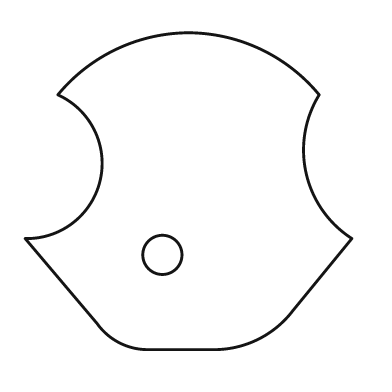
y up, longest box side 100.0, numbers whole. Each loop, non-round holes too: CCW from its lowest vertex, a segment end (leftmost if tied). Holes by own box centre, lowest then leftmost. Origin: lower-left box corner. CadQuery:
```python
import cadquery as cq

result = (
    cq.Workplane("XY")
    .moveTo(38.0, 0.0)
    .lineTo(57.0, 0.0)
    .threePointArc((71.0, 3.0), (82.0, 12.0))
    .lineTo(100.0, 34.0)
    .threePointArc((86.0, 54.0), (90.0, 78.0))
    .threePointArc((72.0, 92.0), (50.0, 97.0))
    .threePointArc((28.0, 92.0), (10.0, 78.0))
    .threePointArc((23.0, 52.0), (0.0, 34.0))
    .lineTo(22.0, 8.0)
    .threePointArc((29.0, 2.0), (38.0, 0.0))
    .close()
    .moveTo(42.0, 29.0)
    .circle(6.0)
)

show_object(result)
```